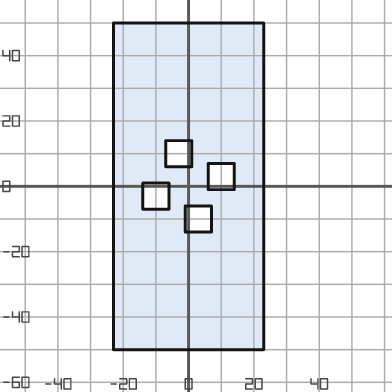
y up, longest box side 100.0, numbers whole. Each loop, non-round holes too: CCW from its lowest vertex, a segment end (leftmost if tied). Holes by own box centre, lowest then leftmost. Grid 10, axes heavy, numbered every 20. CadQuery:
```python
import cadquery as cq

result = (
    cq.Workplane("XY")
    .moveTo(-23.0, -50.0)
    .lineTo(23.0, -50.0)
    .lineTo(23.0, 50.0)
    .lineTo(-23.0, 50.0)
    .close()
    .moveTo(-1.0, -14.0)
    .lineTo(7.0, -14.0)
    .lineTo(7.0, -6.0)
    .lineTo(-1.0, -6.0)
    .close()
    .moveTo(-14.0, -7.0)
    .lineTo(-6.0, -7.0)
    .lineTo(-6.0, 1.0)
    .lineTo(-14.0, 1.0)
    .close()
    .moveTo(6.0, -1.0)
    .lineTo(14.0, -1.0)
    .lineTo(14.0, 7.0)
    .lineTo(6.0, 7.0)
    .close()
    .moveTo(-7.0, 6.0)
    .lineTo(1.0, 6.0)
    .lineTo(1.0, 14.0)
    .lineTo(-7.0, 14.0)
    .close()
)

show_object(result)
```